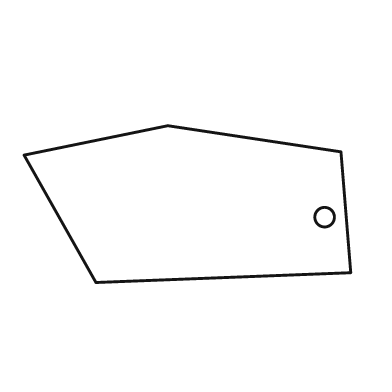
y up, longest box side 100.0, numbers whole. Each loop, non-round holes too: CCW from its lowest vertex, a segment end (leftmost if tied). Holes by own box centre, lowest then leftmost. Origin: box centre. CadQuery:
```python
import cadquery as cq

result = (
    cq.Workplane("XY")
    .moveTo(-28.0, -24.0)
    .lineTo(50.0, -21.0)
    .lineTo(47.0, 16.0)
    .lineTo(-6.0, 24.0)
    .lineTo(-50.0, 15.0)
    .close()
    .moveTo(42.0, -4.0)
    .circle(3.0)
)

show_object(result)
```